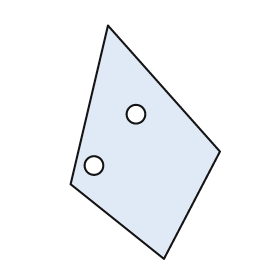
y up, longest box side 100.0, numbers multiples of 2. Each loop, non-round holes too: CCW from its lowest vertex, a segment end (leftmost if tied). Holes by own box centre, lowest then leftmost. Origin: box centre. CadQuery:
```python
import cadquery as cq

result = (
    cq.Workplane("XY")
    .moveTo(8.0, -50.0)
    .lineTo(32.0, -4.0)
    .lineTo(-16.0, 50.0)
    .lineTo(-32.0, -18.0)
    .close()
    .moveTo(-22.0, -10.0)
    .circle(4.0)
    .moveTo(-4.0, 12.0)
    .circle(4.0)
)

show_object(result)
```